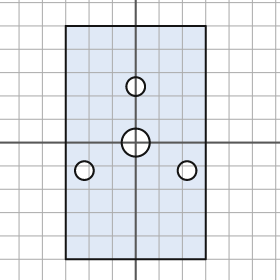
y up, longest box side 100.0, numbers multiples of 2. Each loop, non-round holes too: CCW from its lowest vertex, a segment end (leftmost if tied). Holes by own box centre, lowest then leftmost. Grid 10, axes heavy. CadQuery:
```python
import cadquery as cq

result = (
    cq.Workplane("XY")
    .moveTo(-30.0, -50.0)
    .lineTo(30.0, -50.0)
    .lineTo(30.0, 50.0)
    .lineTo(-30.0, 50.0)
    .close()
    .moveTo(-22.0, -12.0)
    .circle(4.0)
    .moveTo(22.0, -12.0)
    .circle(4.0)
    .moveTo(0.0, 0.0)
    .circle(6.0)
    .moveTo(0.0, 24.0)
    .circle(4.0)
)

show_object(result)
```